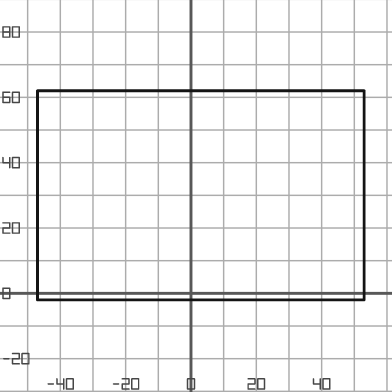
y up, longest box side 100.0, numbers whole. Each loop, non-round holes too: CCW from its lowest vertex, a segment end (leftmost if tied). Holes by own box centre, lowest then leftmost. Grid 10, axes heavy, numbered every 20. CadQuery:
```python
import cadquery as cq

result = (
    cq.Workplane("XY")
    .moveTo(-47.0, -2.0)
    .lineTo(53.0, -2.0)
    .lineTo(53.0, 62.0)
    .lineTo(-47.0, 62.0)
    .close()
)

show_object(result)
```